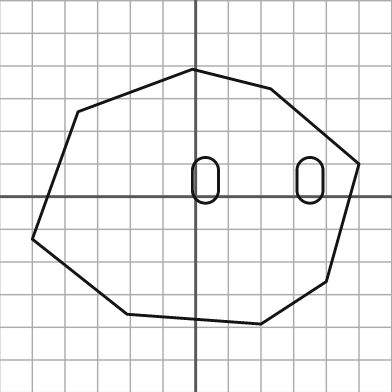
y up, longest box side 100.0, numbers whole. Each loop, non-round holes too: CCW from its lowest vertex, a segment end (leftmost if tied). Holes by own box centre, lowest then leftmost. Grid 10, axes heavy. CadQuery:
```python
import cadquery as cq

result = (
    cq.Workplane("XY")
    .moveTo(20.0, -39.0)
    .lineTo(40.0, -26.0)
    .lineTo(50.0, 10.0)
    .lineTo(23.0, 33.0)
    .lineTo(-1.0, 39.0)
    .lineTo(-36.0, 26.0)
    .lineTo(-50.0, -13.0)
    .lineTo(-21.0, -36.0)
    .close()
    .moveTo(-1.0, 2.0)
    .threePointArc((3.0, -2.0), (7.0, 2.0))
    .lineTo(7.0, 8.0)
    .threePointArc((3.0, 12.0), (-1.0, 8.0))
    .close()
    .moveTo(31.0, 2.0)
    .threePointArc((35.0, -2.0), (39.0, 2.0))
    .lineTo(39.0, 8.0)
    .threePointArc((35.0, 12.0), (31.0, 8.0))
    .close()
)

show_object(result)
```